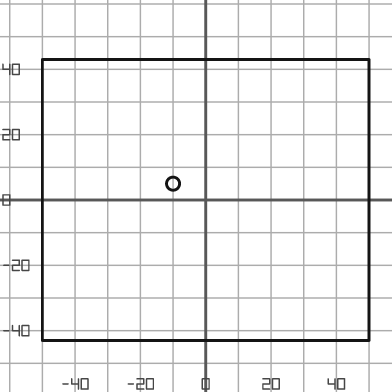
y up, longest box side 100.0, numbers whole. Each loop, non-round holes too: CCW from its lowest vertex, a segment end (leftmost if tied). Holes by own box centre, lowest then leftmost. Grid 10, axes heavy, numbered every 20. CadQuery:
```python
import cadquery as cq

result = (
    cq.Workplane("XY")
    .moveTo(-50.0, -43.0)
    .lineTo(50.0, -43.0)
    .lineTo(50.0, 43.0)
    .lineTo(-50.0, 43.0)
    .close()
    .moveTo(-10.0, 5.0)
    .circle(2.0)
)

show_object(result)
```